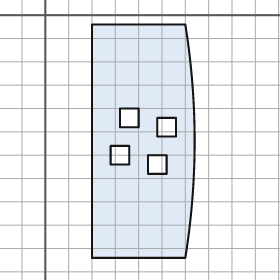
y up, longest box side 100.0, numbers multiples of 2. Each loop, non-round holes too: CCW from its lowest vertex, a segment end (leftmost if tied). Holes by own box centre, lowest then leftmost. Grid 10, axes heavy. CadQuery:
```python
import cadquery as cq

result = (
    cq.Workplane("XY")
    .moveTo(20.0, -104.0)
    .lineTo(60.0, -104.0)
    .threePointArc((64.0, -54.0), (60.0, -4.0))
    .lineTo(20.0, -4.0)
    .close()
    .moveTo(44.0, -68.0)
    .lineTo(52.0, -68.0)
    .lineTo(52.0, -60.0)
    .lineTo(44.0, -60.0)
    .close()
    .moveTo(28.0, -64.0)
    .lineTo(36.0, -64.0)
    .lineTo(36.0, -56.0)
    .lineTo(28.0, -56.0)
    .close()
    .moveTo(48.0, -52.0)
    .lineTo(56.0, -52.0)
    .lineTo(56.0, -44.0)
    .lineTo(48.0, -44.0)
    .close()
    .moveTo(32.0, -48.0)
    .lineTo(40.0, -48.0)
    .lineTo(40.0, -40.0)
    .lineTo(32.0, -40.0)
    .close()
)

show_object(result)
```